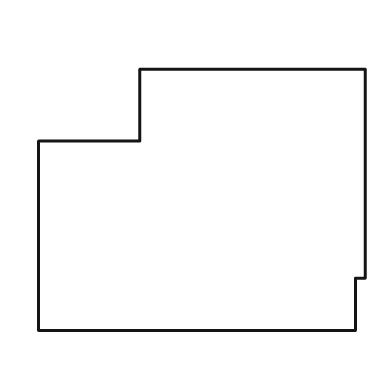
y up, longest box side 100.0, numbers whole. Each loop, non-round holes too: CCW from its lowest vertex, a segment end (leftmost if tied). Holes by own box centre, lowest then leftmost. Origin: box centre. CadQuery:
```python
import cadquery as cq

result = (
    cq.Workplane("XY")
    .moveTo(-50.0, -40.0)
    .lineTo(47.0, -40.0)
    .lineTo(47.0, -24.0)
    .lineTo(50.0, -24.0)
    .lineTo(50.0, 40.0)
    .lineTo(-19.0, 40.0)
    .lineTo(-19.0, 18.0)
    .lineTo(-50.0, 18.0)
    .close()
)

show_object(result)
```